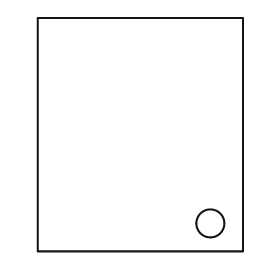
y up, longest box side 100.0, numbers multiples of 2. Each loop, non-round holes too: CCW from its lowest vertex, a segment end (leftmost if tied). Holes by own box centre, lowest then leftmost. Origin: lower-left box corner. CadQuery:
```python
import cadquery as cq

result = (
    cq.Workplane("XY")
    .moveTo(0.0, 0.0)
    .lineTo(88.0, 0.0)
    .lineTo(88.0, 100.0)
    .lineTo(0.0, 100.0)
    .close()
    .moveTo(74.0, 12.0)
    .circle(6.0)
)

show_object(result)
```